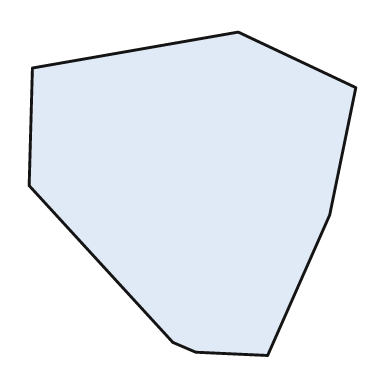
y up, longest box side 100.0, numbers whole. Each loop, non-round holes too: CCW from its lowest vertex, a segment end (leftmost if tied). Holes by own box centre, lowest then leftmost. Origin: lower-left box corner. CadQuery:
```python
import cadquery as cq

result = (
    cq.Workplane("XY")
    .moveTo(73.0, 0.0)
    .lineTo(92.0, 43.0)
    .lineTo(100.0, 82.0)
    .lineTo(64.0, 99.0)
    .lineTo(1.0, 88.0)
    .lineTo(0.0, 52.0)
    .lineTo(44.0, 4.0)
    .lineTo(51.0, 1.0)
    .close()
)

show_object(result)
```